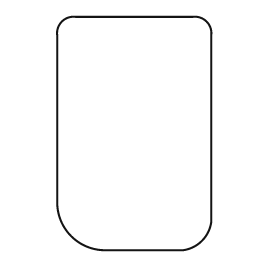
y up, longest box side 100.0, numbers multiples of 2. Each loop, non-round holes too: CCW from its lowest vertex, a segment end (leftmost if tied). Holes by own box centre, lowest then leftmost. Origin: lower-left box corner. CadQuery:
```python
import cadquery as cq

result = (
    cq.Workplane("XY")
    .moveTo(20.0, 0.0)
    .lineTo(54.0, 0.0)
    .threePointArc((62.0, 4.0), (66.0, 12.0))
    .lineTo(66.0, 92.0)
    .threePointArc((64.0, 98.0), (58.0, 100.0))
    .lineTo(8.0, 100.0)
    .threePointArc((2.0, 98.0), (0.0, 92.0))
    .lineTo(0.0, 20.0)
    .threePointArc((6.0, 6.0), (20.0, 0.0))
    .close()
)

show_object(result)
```